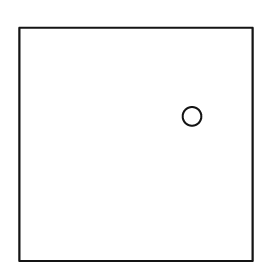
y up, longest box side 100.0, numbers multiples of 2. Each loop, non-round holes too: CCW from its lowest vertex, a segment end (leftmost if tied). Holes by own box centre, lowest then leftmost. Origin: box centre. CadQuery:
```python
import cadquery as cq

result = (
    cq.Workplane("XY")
    .moveTo(-50.0, -50.0)
    .lineTo(50.0, -50.0)
    .lineTo(50.0, 50.0)
    .lineTo(-50.0, 50.0)
    .close()
    .moveTo(24.0, 12.0)
    .circle(4.0)
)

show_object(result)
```